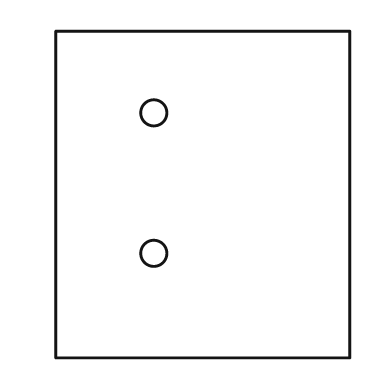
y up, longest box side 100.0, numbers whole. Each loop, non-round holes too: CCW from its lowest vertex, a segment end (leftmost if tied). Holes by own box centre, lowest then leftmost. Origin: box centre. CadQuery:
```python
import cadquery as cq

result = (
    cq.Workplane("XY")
    .moveTo(-45.0, -50.0)
    .lineTo(45.0, -50.0)
    .lineTo(45.0, 50.0)
    .lineTo(-45.0, 50.0)
    .close()
    .moveTo(-15.0, -18.0)
    .circle(4.0)
    .moveTo(-15.0, 25.0)
    .circle(4.0)
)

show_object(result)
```